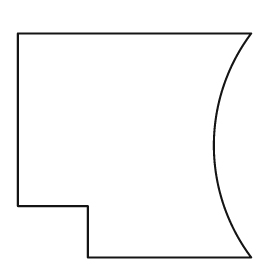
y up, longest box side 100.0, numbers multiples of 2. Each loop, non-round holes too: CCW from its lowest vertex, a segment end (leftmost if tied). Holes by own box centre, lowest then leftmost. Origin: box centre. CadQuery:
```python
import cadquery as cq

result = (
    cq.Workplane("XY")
    .moveTo(-20.0, -48.0)
    .lineTo(50.0, -48.0)
    .threePointArc((34.0, 0.0), (50.0, 48.0))
    .lineTo(-50.0, 48.0)
    .lineTo(-50.0, -26.0)
    .lineTo(-20.0, -26.0)
    .close()
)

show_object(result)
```